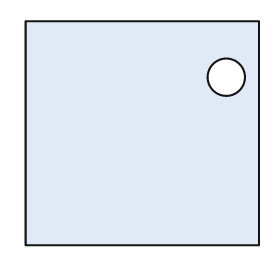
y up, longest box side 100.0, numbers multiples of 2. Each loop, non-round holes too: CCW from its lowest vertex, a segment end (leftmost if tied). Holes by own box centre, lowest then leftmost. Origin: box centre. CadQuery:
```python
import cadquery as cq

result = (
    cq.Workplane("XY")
    .moveTo(-50.0, -48.0)
    .lineTo(50.0, -48.0)
    .lineTo(50.0, 48.0)
    .lineTo(-50.0, 48.0)
    .close()
    .moveTo(36.0, 24.0)
    .circle(8.0)
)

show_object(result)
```